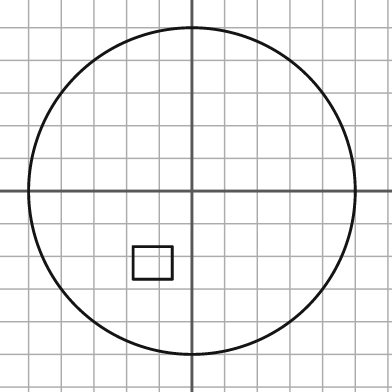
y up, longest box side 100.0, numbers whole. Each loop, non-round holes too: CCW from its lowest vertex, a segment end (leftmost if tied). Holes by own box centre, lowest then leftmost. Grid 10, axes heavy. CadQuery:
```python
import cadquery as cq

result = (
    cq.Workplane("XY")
    .moveTo(0.0, 0.0)
    .circle(50.0)
    .moveTo(-18.0, -27.0)
    .lineTo(-6.0, -27.0)
    .lineTo(-6.0, -17.0)
    .lineTo(-18.0, -17.0)
    .close()
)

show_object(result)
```